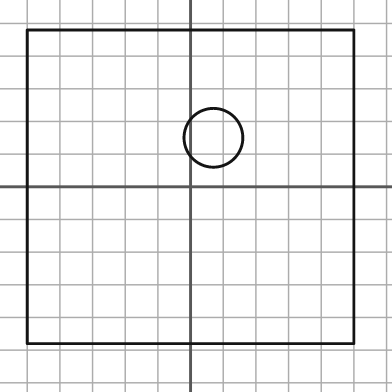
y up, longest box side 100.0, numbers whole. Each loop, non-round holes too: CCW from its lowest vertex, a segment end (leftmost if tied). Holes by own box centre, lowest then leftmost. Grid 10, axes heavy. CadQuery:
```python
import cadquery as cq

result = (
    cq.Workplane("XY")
    .moveTo(-50.0, -48.0)
    .lineTo(50.0, -48.0)
    .lineTo(50.0, 48.0)
    .lineTo(-50.0, 48.0)
    .close()
    .moveTo(7.0, 15.0)
    .circle(9.0)
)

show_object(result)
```